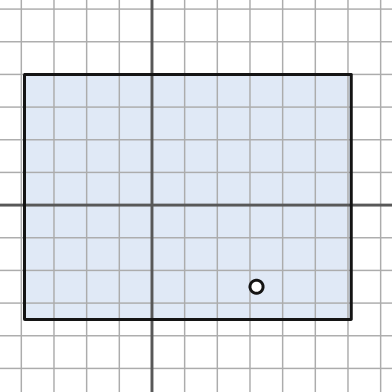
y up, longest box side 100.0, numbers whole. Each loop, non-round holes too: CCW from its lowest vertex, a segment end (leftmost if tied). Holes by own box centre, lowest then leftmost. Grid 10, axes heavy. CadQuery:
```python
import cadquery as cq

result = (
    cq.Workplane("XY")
    .moveTo(-39.0, -35.0)
    .lineTo(61.0, -35.0)
    .lineTo(61.0, 40.0)
    .lineTo(-39.0, 40.0)
    .close()
    .moveTo(32.0, -25.0)
    .circle(2.0)
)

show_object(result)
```